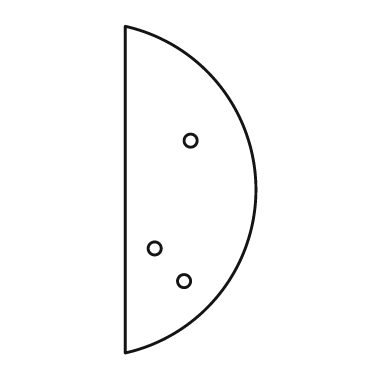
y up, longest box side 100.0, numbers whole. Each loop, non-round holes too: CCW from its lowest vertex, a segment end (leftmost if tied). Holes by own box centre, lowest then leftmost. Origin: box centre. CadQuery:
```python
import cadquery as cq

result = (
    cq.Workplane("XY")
    .moveTo(-20.0, -50.0)
    .threePointArc((20.0, 0.0), (-20.0, 50.0))
    .close()
    .moveTo(-2.0, -28.0)
    .circle(2.0)
    .moveTo(-11.0, -18.0)
    .circle(2.0)
    .moveTo(0.0, 15.0)
    .circle(2.0)
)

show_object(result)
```